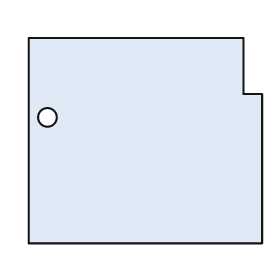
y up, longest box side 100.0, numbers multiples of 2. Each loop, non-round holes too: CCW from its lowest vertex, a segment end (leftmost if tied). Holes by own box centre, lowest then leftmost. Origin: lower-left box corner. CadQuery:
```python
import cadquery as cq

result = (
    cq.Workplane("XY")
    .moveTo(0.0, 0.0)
    .lineTo(100.0, 0.0)
    .lineTo(100.0, 64.0)
    .lineTo(92.0, 64.0)
    .lineTo(92.0, 88.0)
    .lineTo(0.0, 88.0)
    .close()
    .moveTo(8.0, 54.0)
    .circle(4.0)
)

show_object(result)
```